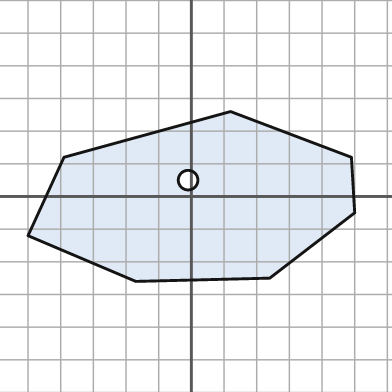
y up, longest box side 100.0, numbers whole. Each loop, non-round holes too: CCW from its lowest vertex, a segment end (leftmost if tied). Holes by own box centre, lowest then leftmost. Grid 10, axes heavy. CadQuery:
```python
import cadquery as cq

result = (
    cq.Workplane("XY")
    .moveTo(-17.0, -26.0)
    .lineTo(24.0, -25.0)
    .lineTo(50.0, -5.0)
    .lineTo(49.0, 12.0)
    .lineTo(12.0, 26.0)
    .lineTo(-39.0, 12.0)
    .lineTo(-50.0, -12.0)
    .close()
    .moveTo(-1.0, 5.0)
    .circle(3.0)
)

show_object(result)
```